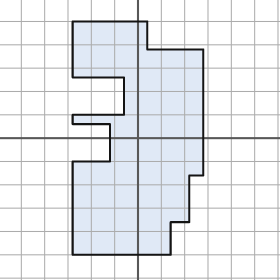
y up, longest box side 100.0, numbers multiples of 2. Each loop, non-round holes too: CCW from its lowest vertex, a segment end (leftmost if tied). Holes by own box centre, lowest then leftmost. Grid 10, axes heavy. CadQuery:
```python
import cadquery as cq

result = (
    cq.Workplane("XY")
    .moveTo(-28.0, -50.0)
    .lineTo(14.0, -50.0)
    .lineTo(14.0, -36.0)
    .lineTo(22.0, -36.0)
    .lineTo(22.0, -16.0)
    .lineTo(28.0, -16.0)
    .lineTo(28.0, 38.0)
    .lineTo(4.0, 38.0)
    .lineTo(4.0, 50.0)
    .lineTo(-28.0, 50.0)
    .lineTo(-28.0, 26.0)
    .lineTo(-6.0, 26.0)
    .lineTo(-6.0, 10.0)
    .lineTo(-28.0, 10.0)
    .lineTo(-28.0, 6.0)
    .lineTo(-12.0, 6.0)
    .lineTo(-12.0, -10.0)
    .lineTo(-28.0, -10.0)
    .close()
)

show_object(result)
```